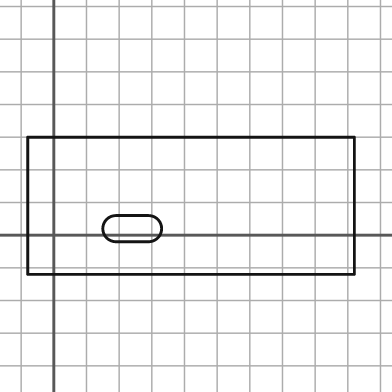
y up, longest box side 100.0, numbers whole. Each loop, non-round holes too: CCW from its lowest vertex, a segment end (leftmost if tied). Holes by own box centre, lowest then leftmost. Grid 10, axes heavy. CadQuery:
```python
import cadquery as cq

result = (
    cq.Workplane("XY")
    .moveTo(-8.0, -12.0)
    .lineTo(92.0, -12.0)
    .lineTo(92.0, 30.0)
    .lineTo(-8.0, 30.0)
    .close()
    .moveTo(19.0, -2.0)
    .lineTo(29.0, -2.0)
    .threePointArc((33.0, 2.0), (29.0, 6.0))
    .lineTo(19.0, 6.0)
    .threePointArc((15.0, 2.0), (19.0, -2.0))
    .close()
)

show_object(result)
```